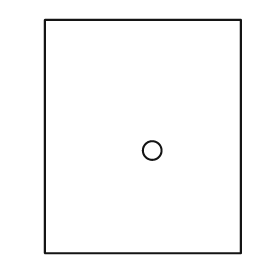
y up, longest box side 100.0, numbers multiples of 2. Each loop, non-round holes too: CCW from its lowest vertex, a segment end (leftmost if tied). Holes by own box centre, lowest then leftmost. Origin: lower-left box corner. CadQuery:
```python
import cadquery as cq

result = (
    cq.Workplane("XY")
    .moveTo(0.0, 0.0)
    .lineTo(84.0, 0.0)
    .lineTo(84.0, 100.0)
    .lineTo(0.0, 100.0)
    .close()
    .moveTo(46.0, 44.0)
    .circle(4.0)
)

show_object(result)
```